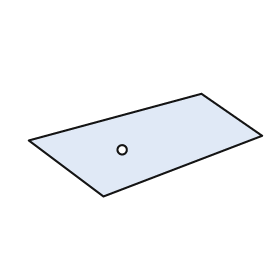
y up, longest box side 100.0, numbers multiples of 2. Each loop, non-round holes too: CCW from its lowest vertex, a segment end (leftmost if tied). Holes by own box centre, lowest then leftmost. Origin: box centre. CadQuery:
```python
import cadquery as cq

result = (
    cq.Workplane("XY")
    .moveTo(-18.0, -22.0)
    .lineTo(50.0, 4.0)
    .lineTo(24.0, 22.0)
    .lineTo(-50.0, 2.0)
    .close()
    .moveTo(-10.0, -2.0)
    .circle(2.0)
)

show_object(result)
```